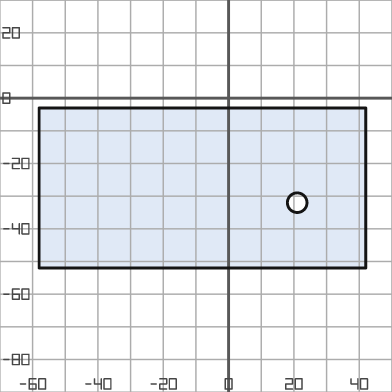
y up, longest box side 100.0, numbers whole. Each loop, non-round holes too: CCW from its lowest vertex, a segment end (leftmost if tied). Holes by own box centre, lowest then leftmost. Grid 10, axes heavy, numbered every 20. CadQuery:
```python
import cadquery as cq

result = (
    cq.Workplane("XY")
    .moveTo(-58.0, -52.0)
    .lineTo(42.0, -52.0)
    .lineTo(42.0, -3.0)
    .lineTo(-58.0, -3.0)
    .close()
    .moveTo(21.0, -32.0)
    .circle(3.0)
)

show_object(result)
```